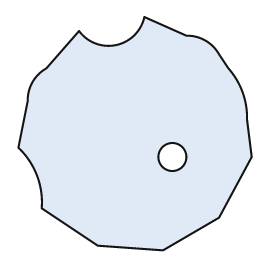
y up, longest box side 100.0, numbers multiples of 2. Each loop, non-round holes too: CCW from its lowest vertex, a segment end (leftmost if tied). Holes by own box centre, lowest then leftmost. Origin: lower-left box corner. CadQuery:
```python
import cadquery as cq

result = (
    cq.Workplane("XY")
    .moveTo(62.0, 0.0)
    .lineTo(86.0, 14.0)
    .lineTo(100.0, 40.0)
    .lineTo(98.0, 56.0)
    .threePointArc((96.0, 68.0), (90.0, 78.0))
    .lineTo(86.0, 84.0)
    .threePointArc((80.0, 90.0), (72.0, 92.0))
    .lineTo(54.0, 100.0)
    .threePointArc((42.0, 88.0), (26.0, 94.0))
    .lineTo(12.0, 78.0)
    .threePointArc((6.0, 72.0), (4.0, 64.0))
    .lineTo(0.0, 44.0)
    .threePointArc((8.0, 32.0), (10.0, 18.0))
    .lineTo(34.0, 2.0)
    .close()
    .moveTo(66.0, 40.0)
    .circle(6.0)
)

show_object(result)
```